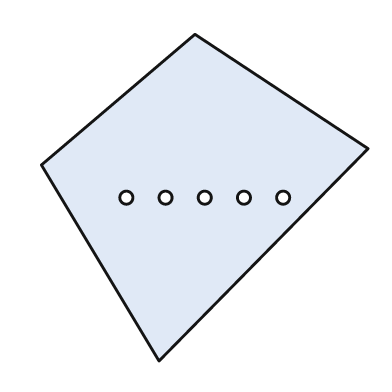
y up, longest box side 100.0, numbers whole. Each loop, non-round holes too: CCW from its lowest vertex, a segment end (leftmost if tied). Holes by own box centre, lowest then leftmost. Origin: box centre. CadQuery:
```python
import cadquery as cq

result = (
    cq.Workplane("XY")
    .moveTo(-14.0, -50.0)
    .lineTo(50.0, 15.0)
    .lineTo(-3.0, 50.0)
    .lineTo(-50.0, 10.0)
    .close()
    .moveTo(-24.0, 0.0)
    .circle(2.0)
    .moveTo(-12.0, 0.0)
    .circle(2.0)
    .moveTo(0.0, 0.0)
    .circle(2.0)
    .moveTo(12.0, 0.0)
    .circle(2.0)
    .moveTo(24.0, 0.0)
    .circle(2.0)
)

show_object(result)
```